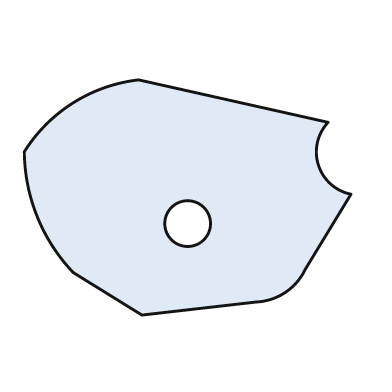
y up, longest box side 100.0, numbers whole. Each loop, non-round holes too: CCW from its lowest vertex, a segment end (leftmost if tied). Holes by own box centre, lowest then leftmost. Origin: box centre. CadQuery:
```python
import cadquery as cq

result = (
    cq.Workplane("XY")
    .moveTo(-14.0, -36.0)
    .lineTo(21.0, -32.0)
    .threePointArc((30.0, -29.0), (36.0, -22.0))
    .lineTo(50.0, 1.0)
    .threePointArc((40.0, 10.0), (43.0, 23.0))
    .lineTo(-15.0, 36.0)
    .threePointArc((-35.0, 29.0), (-50.0, 14.0))
    .threePointArc((-46.0, -6.0), (-35.0, -23.0))
    .close()
    .moveTo(0.0, -8.0)
    .circle(7.0)
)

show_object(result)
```